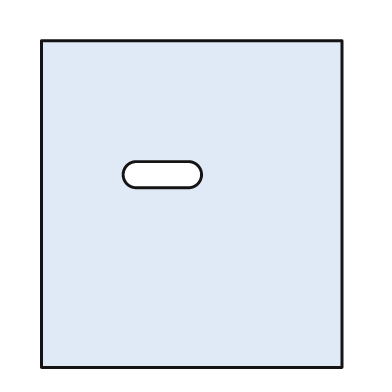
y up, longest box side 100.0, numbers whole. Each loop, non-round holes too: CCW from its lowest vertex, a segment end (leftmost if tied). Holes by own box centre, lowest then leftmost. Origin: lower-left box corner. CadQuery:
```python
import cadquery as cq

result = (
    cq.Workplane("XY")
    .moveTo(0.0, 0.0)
    .lineTo(92.0, 0.0)
    .lineTo(92.0, 100.0)
    .lineTo(0.0, 100.0)
    .close()
    .moveTo(29.0, 55.0)
    .lineTo(45.0, 55.0)
    .threePointArc((49.0, 59.0), (45.0, 63.0))
    .lineTo(29.0, 63.0)
    .threePointArc((25.0, 59.0), (29.0, 55.0))
    .close()
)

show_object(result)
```